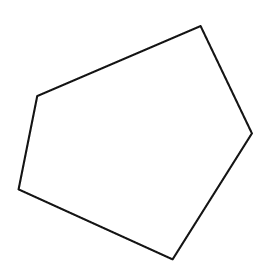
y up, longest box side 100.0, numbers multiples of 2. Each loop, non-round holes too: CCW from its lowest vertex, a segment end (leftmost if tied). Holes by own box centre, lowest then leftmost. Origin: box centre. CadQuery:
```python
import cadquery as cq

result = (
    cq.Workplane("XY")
    .moveTo(16.0, -50.0)
    .lineTo(50.0, 4.0)
    .lineTo(28.0, 50.0)
    .lineTo(-42.0, 20.0)
    .lineTo(-50.0, -20.0)
    .close()
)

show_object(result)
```